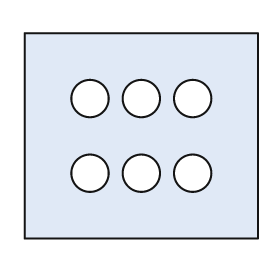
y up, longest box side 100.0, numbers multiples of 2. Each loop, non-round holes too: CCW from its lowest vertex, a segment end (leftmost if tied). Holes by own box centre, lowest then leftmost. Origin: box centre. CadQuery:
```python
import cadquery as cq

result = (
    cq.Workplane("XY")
    .moveTo(-50.0, -44.0)
    .lineTo(50.0, -44.0)
    .lineTo(50.0, 44.0)
    .lineTo(-50.0, 44.0)
    .close()
    .moveTo(-22.0, -16.0)
    .circle(8.0)
    .moveTo(0.0, -16.0)
    .circle(8.0)
    .moveTo(22.0, -16.0)
    .circle(8.0)
    .moveTo(-22.0, 16.0)
    .circle(8.0)
    .moveTo(0.0, 16.0)
    .circle(8.0)
    .moveTo(22.0, 16.0)
    .circle(8.0)
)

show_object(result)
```